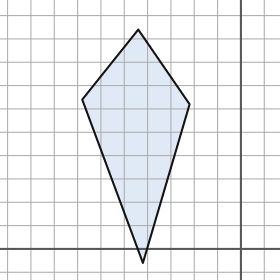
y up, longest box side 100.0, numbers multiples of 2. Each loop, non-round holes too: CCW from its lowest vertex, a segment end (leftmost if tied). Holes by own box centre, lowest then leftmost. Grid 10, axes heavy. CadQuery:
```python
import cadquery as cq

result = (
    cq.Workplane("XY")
    .moveTo(-42.0, -6.0)
    .lineTo(-22.0, 62.0)
    .lineTo(-44.0, 94.0)
    .lineTo(-68.0, 64.0)
    .close()
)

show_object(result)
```